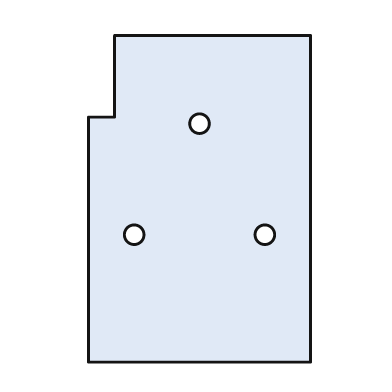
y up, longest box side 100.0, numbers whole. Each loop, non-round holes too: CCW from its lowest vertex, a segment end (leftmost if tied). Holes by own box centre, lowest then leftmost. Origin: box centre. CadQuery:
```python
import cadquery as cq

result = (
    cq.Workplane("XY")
    .moveTo(-34.0, -50.0)
    .lineTo(34.0, -50.0)
    .lineTo(34.0, 50.0)
    .lineTo(-26.0, 50.0)
    .lineTo(-26.0, 25.0)
    .lineTo(-34.0, 25.0)
    .close()
    .moveTo(-20.0, -11.0)
    .circle(3.0)
    .moveTo(20.0, -11.0)
    .circle(3.0)
    .moveTo(0.0, 23.0)
    .circle(3.0)
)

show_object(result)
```